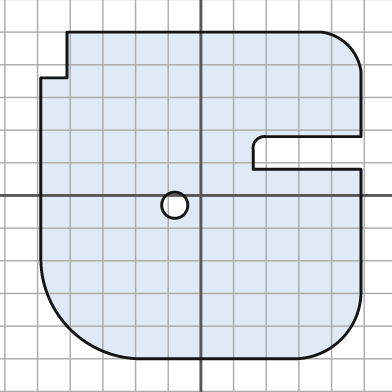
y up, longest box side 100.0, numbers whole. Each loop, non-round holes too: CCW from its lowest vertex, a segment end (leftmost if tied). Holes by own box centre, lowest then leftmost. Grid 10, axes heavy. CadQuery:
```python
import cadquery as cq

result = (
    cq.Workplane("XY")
    .moveTo(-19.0, -50.0)
    .lineTo(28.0, -50.0)
    .threePointArc((43.0, -44.0), (49.0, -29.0))
    .lineTo(49.0, 8.0)
    .lineTo(16.0, 8.0)
    .lineTo(16.0, 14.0)
    .threePointArc((17.0, 17.0), (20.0, 18.0))
    .lineTo(49.0, 18.0)
    .lineTo(49.0, 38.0)
    .threePointArc((45.0, 46.0), (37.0, 50.0))
    .lineTo(-41.0, 50.0)
    .lineTo(-41.0, 36.0)
    .lineTo(-49.0, 36.0)
    .lineTo(-49.0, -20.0)
    .threePointArc((-40.0, -41.0), (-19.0, -50.0))
    .close()
    .moveTo(-8.0, -3.0)
    .circle(4.0)
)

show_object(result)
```